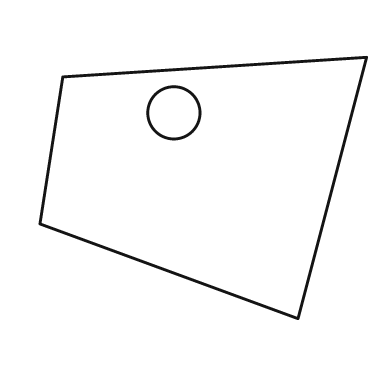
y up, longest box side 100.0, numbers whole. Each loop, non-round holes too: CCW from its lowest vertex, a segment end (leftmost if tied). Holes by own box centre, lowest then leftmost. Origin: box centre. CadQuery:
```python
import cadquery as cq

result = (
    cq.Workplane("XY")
    .moveTo(29.0, -40.0)
    .lineTo(50.0, 40.0)
    .lineTo(-43.0, 34.0)
    .lineTo(-50.0, -11.0)
    .close()
    .moveTo(-9.0, 23.0)
    .circle(8.0)
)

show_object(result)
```